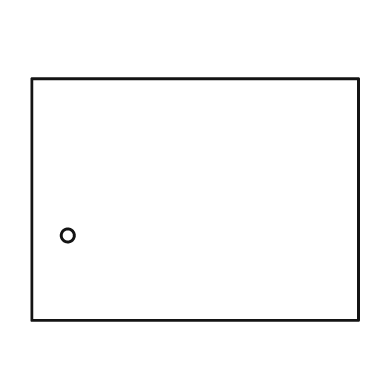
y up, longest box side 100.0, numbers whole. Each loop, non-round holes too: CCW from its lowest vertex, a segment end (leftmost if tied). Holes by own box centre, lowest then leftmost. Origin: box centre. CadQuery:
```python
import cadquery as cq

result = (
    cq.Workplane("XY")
    .moveTo(-50.0, -37.0)
    .lineTo(50.0, -37.0)
    .lineTo(50.0, 37.0)
    .lineTo(-50.0, 37.0)
    .close()
    .moveTo(-39.0, -11.0)
    .circle(2.0)
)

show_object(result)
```